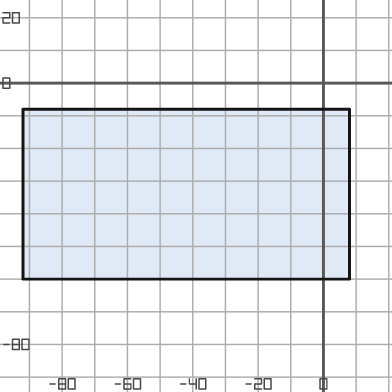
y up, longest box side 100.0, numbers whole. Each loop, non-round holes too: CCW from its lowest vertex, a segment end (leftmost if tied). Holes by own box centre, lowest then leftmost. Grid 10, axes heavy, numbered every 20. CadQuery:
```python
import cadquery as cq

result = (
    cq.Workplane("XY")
    .moveTo(-92.0, -60.0)
    .lineTo(8.0, -60.0)
    .lineTo(8.0, -8.0)
    .lineTo(-92.0, -8.0)
    .close()
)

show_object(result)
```